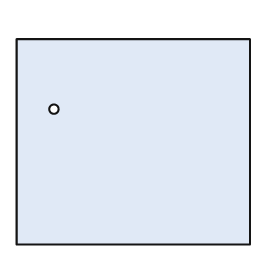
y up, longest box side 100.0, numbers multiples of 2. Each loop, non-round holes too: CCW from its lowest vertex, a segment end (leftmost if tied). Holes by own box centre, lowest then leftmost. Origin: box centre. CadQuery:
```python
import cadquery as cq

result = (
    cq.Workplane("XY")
    .moveTo(-50.0, -44.0)
    .lineTo(50.0, -44.0)
    .lineTo(50.0, 44.0)
    .lineTo(-50.0, 44.0)
    .close()
    .moveTo(-34.0, 14.0)
    .circle(2.0)
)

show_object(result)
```